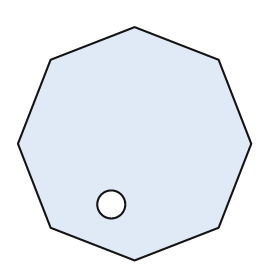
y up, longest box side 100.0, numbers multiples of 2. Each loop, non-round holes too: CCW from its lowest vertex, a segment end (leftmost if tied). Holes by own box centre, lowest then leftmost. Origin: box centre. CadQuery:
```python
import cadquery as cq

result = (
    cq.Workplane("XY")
    .moveTo(0.0, -50.0)
    .lineTo(36.0, -36.0)
    .lineTo(50.0, 0.0)
    .lineTo(36.0, 36.0)
    .lineTo(0.0, 50.0)
    .lineTo(-36.0, 36.0)
    .lineTo(-50.0, 0.0)
    .lineTo(-36.0, -36.0)
    .close()
    .moveTo(-10.0, -26.0)
    .circle(6.0)
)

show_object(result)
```